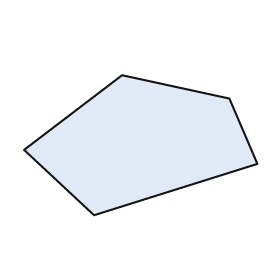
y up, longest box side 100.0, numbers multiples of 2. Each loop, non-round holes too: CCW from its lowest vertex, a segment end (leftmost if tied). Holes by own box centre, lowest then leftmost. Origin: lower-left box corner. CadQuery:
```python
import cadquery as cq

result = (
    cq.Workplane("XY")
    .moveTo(30.0, 0.0)
    .lineTo(100.0, 22.0)
    .lineTo(88.0, 50.0)
    .lineTo(42.0, 60.0)
    .lineTo(0.0, 28.0)
    .close()
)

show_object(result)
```